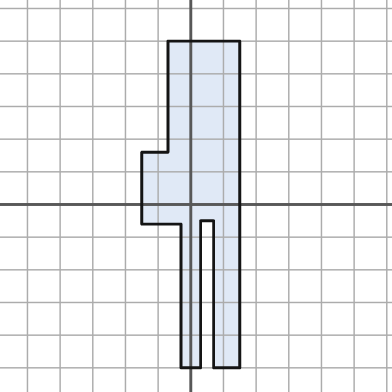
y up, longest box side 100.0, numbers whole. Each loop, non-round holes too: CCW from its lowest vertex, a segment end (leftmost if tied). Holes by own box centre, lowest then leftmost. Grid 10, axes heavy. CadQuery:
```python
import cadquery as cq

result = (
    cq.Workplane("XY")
    .moveTo(-3.0, -50.0)
    .lineTo(3.0, -50.0)
    .lineTo(3.0, -5.0)
    .lineTo(7.0, -5.0)
    .lineTo(7.0, -50.0)
    .lineTo(15.0, -50.0)
    .lineTo(15.0, 50.0)
    .lineTo(-7.0, 50.0)
    .lineTo(-7.0, 16.0)
    .lineTo(-15.0, 16.0)
    .lineTo(-15.0, -6.0)
    .lineTo(-3.0, -6.0)
    .close()
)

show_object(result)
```